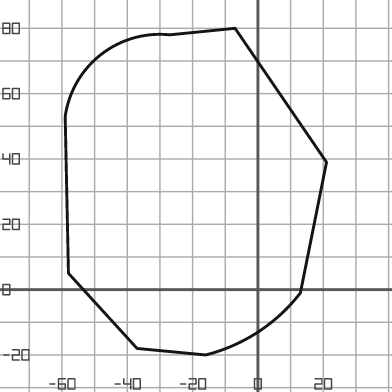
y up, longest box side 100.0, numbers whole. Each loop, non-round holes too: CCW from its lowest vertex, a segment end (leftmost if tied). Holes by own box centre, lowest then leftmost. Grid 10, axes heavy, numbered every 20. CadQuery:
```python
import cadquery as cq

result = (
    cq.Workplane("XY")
    .moveTo(-16.0, -20.0)
    .threePointArc((0.0, -13.0), (13.0, -1.0))
    .lineTo(21.0, 39.0)
    .lineTo(-7.0, 80.0)
    .lineTo(-27.0, 78.0)
    .threePointArc((-48.0, 72.0), (-59.0, 53.0))
    .lineTo(-58.0, 5.0)
    .lineTo(-37.0, -18.0)
    .close()
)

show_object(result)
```